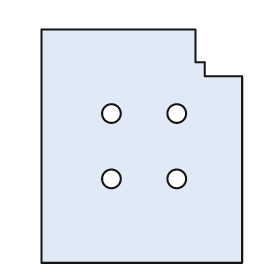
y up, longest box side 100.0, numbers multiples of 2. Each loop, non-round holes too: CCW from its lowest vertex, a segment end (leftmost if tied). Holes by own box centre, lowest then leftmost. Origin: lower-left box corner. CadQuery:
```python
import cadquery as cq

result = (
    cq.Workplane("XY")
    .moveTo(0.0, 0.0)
    .lineTo(86.0, 0.0)
    .lineTo(86.0, 80.0)
    .lineTo(70.0, 80.0)
    .lineTo(70.0, 86.0)
    .lineTo(66.0, 86.0)
    .lineTo(66.0, 100.0)
    .lineTo(0.0, 100.0)
    .close()
    .moveTo(30.0, 36.0)
    .circle(4.0)
    .moveTo(58.0, 36.0)
    .circle(4.0)
    .moveTo(30.0, 64.0)
    .circle(4.0)
    .moveTo(58.0, 64.0)
    .circle(4.0)
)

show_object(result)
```